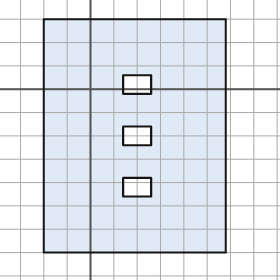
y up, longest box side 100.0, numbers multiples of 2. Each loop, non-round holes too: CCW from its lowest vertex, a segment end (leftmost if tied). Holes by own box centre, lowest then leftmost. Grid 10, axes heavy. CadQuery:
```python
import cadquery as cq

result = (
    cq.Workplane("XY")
    .moveTo(-20.0, -70.0)
    .lineTo(58.0, -70.0)
    .lineTo(58.0, 30.0)
    .lineTo(-20.0, 30.0)
    .close()
    .moveTo(14.0, -46.0)
    .lineTo(26.0, -46.0)
    .lineTo(26.0, -38.0)
    .lineTo(14.0, -38.0)
    .close()
    .moveTo(14.0, -24.0)
    .lineTo(26.0, -24.0)
    .lineTo(26.0, -16.0)
    .lineTo(14.0, -16.0)
    .close()
    .moveTo(14.0, -2.0)
    .lineTo(26.0, -2.0)
    .lineTo(26.0, 6.0)
    .lineTo(14.0, 6.0)
    .close()
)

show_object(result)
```